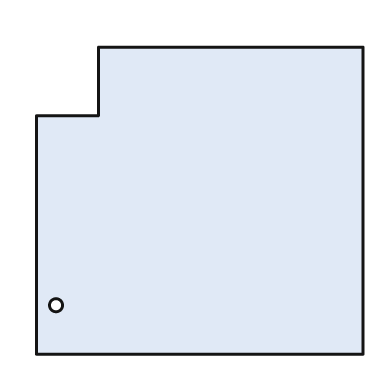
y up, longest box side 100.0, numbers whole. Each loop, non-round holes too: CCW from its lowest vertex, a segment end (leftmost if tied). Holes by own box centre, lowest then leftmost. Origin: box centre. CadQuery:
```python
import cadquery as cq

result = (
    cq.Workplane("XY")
    .moveTo(-50.0, -47.0)
    .lineTo(50.0, -47.0)
    .lineTo(50.0, 47.0)
    .lineTo(-31.0, 47.0)
    .lineTo(-31.0, 26.0)
    .lineTo(-50.0, 26.0)
    .close()
    .moveTo(-44.0, -32.0)
    .circle(2.0)
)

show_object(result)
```